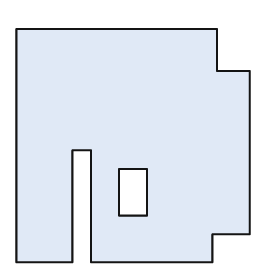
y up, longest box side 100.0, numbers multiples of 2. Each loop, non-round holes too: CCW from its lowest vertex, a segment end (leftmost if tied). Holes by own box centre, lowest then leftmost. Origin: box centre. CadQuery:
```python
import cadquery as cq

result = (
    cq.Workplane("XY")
    .moveTo(-50.0, -50.0)
    .lineTo(-26.0, -50.0)
    .lineTo(-26.0, -2.0)
    .lineTo(-18.0, -2.0)
    .lineTo(-18.0, -50.0)
    .lineTo(34.0, -50.0)
    .lineTo(34.0, -38.0)
    .lineTo(50.0, -38.0)
    .lineTo(50.0, 32.0)
    .lineTo(36.0, 32.0)
    .lineTo(36.0, 50.0)
    .lineTo(-50.0, 50.0)
    .close()
    .moveTo(-6.0, -30.0)
    .lineTo(6.0, -30.0)
    .lineTo(6.0, -10.0)
    .lineTo(-6.0, -10.0)
    .close()
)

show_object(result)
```